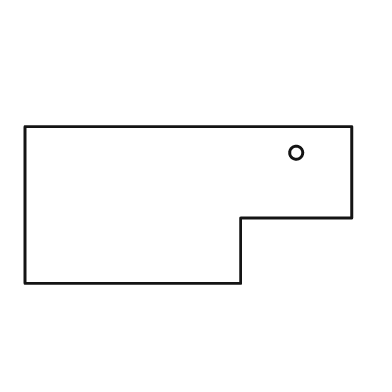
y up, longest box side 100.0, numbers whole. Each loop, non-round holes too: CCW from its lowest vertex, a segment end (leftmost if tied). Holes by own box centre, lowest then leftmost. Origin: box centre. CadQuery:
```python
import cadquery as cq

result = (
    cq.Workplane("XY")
    .moveTo(-50.0, -24.0)
    .lineTo(16.0, -24.0)
    .lineTo(16.0, -4.0)
    .lineTo(50.0, -4.0)
    .lineTo(50.0, 24.0)
    .lineTo(-50.0, 24.0)
    .close()
    .moveTo(33.0, 16.0)
    .circle(2.0)
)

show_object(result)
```